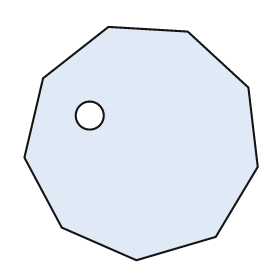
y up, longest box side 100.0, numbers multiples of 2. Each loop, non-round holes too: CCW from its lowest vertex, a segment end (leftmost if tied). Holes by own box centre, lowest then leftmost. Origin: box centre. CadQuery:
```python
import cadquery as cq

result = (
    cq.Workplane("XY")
    .moveTo(-2.0, -50.0)
    .lineTo(32.0, -40.0)
    .lineTo(50.0, -10.0)
    .lineTo(46.0, 24.0)
    .lineTo(20.0, 48.0)
    .lineTo(-14.0, 50.0)
    .lineTo(-42.0, 28.0)
    .lineTo(-50.0, -6.0)
    .lineTo(-34.0, -36.0)
    .close()
    .moveTo(-22.0, 12.0)
    .circle(6.0)
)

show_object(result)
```